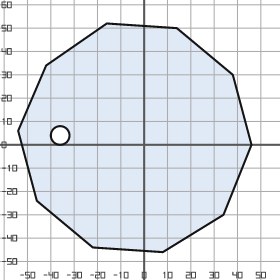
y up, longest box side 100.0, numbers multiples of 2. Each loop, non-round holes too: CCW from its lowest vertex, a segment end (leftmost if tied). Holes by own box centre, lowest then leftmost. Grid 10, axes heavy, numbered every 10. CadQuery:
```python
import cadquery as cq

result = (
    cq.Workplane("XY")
    .moveTo(8.0, -46.0)
    .lineTo(34.0, -30.0)
    .lineTo(46.0, 0.0)
    .lineTo(38.0, 30.0)
    .lineTo(14.0, 50.0)
    .lineTo(-16.0, 52.0)
    .lineTo(-42.0, 34.0)
    .lineTo(-54.0, 6.0)
    .lineTo(-46.0, -24.0)
    .lineTo(-22.0, -44.0)
    .close()
    .moveTo(-36.0, 4.0)
    .circle(4.0)
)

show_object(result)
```